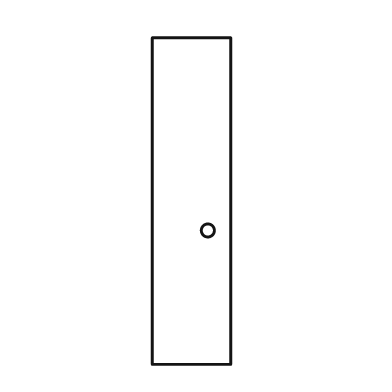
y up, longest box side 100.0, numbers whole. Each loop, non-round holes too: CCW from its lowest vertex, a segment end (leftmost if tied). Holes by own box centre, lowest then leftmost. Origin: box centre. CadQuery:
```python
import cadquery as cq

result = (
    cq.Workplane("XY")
    .moveTo(-12.0, -50.0)
    .lineTo(12.0, -50.0)
    .lineTo(12.0, 50.0)
    .lineTo(-12.0, 50.0)
    .close()
    .moveTo(5.0, -9.0)
    .circle(2.0)
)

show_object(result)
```